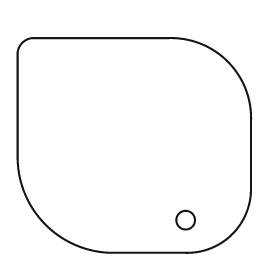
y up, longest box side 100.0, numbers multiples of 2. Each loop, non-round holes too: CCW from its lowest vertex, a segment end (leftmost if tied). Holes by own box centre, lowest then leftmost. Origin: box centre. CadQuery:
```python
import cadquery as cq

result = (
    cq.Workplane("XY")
    .moveTo(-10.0, -46.0)
    .lineTo(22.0, -46.0)
    .threePointArc((42.0, -38.0), (50.0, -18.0))
    .lineTo(50.0, 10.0)
    .threePointArc((40.0, 36.0), (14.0, 46.0))
    .lineTo(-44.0, 46.0)
    .threePointArc((-48.0, 44.0), (-50.0, 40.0))
    .lineTo(-50.0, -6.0)
    .threePointArc((-38.0, -34.0), (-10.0, -46.0))
    .close()
    .moveTo(22.0, -32.0)
    .circle(4.0)
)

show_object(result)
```